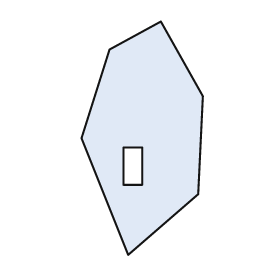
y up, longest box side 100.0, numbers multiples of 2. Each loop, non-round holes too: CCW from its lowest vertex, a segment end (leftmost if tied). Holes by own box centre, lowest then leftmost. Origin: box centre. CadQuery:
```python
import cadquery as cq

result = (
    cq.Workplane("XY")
    .moveTo(-6.0, -50.0)
    .lineTo(24.0, -24.0)
    .lineTo(26.0, 18.0)
    .lineTo(8.0, 50.0)
    .lineTo(-14.0, 38.0)
    .lineTo(-26.0, 0.0)
    .close()
    .moveTo(-8.0, -20.0)
    .lineTo(0.0, -20.0)
    .lineTo(0.0, -4.0)
    .lineTo(-8.0, -4.0)
    .close()
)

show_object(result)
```